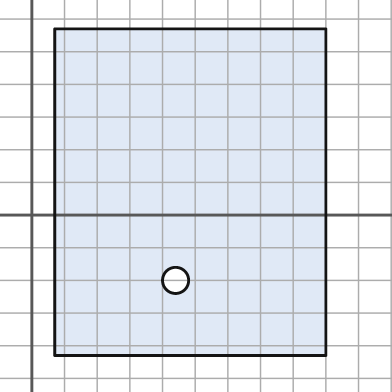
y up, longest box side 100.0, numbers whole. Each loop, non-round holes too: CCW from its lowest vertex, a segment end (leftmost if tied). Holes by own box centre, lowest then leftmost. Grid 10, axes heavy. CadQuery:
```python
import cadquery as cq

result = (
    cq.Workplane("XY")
    .moveTo(7.0, -43.0)
    .lineTo(90.0, -43.0)
    .lineTo(90.0, 57.0)
    .lineTo(7.0, 57.0)
    .close()
    .moveTo(44.0, -20.0)
    .circle(4.0)
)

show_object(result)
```